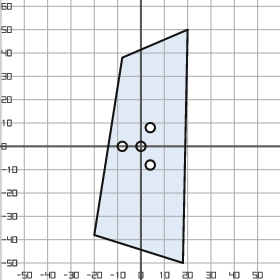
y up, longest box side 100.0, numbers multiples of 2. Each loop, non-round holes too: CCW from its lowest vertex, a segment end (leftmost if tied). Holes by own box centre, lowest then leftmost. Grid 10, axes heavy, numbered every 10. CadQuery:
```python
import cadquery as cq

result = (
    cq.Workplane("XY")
    .moveTo(18.0, -50.0)
    .lineTo(20.0, 50.0)
    .lineTo(-8.0, 38.0)
    .lineTo(-20.0, -38.0)
    .close()
    .moveTo(4.0, -8.0)
    .circle(2.0)
    .moveTo(-8.0, 0.0)
    .circle(2.0)
    .moveTo(0.0, 0.0)
    .circle(2.0)
    .moveTo(4.0, 8.0)
    .circle(2.0)
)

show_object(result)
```